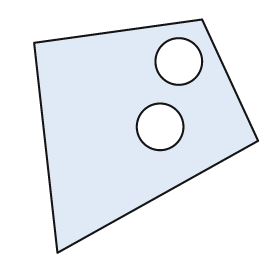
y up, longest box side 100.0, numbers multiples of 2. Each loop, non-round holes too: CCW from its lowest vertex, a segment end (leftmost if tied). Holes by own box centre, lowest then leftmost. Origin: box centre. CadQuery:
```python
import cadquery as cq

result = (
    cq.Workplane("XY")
    .moveTo(-38.0, -50.0)
    .lineTo(48.0, -2.0)
    .lineTo(24.0, 50.0)
    .lineTo(-48.0, 40.0)
    .close()
    .moveTo(6.0, 4.0)
    .circle(10.0)
    .moveTo(14.0, 32.0)
    .circle(10.0)
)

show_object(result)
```